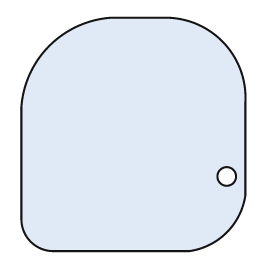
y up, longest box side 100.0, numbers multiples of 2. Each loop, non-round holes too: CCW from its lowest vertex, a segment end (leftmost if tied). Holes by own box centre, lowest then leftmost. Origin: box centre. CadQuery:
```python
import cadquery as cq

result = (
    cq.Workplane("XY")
    .moveTo(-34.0, -50.0)
    .lineTo(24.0, -50.0)
    .threePointArc((40.0, -42.0), (48.0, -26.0))
    .lineTo(48.0, 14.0)
    .threePointArc((38.0, 40.0), (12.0, 50.0))
    .lineTo(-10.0, 50.0)
    .threePointArc((-36.0, 38.0), (-48.0, 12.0))
    .lineTo(-48.0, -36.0)
    .threePointArc((-44.0, -46.0), (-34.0, -50.0))
    .close()
    .moveTo(40.0, -18.0)
    .circle(4.0)
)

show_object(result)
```